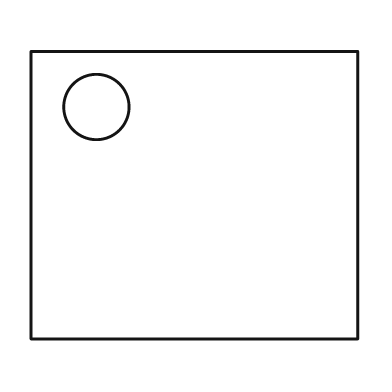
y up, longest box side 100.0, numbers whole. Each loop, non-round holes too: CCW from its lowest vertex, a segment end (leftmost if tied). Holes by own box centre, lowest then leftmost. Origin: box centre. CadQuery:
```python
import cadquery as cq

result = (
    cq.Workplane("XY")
    .moveTo(-50.0, -44.0)
    .lineTo(50.0, -44.0)
    .lineTo(50.0, 44.0)
    .lineTo(-50.0, 44.0)
    .close()
    .moveTo(-30.0, 27.0)
    .circle(10.0)
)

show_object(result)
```